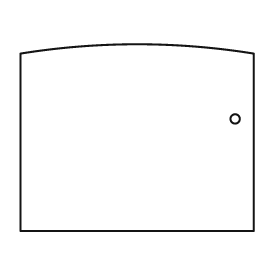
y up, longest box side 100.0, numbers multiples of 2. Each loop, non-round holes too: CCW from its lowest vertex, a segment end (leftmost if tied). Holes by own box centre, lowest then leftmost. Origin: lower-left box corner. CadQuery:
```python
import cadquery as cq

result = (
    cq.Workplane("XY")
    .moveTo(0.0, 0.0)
    .lineTo(100.0, 0.0)
    .lineTo(100.0, 76.0)
    .threePointArc((50.0, 80.0), (0.0, 76.0))
    .close()
    .moveTo(92.0, 48.0)
    .circle(2.0)
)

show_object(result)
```